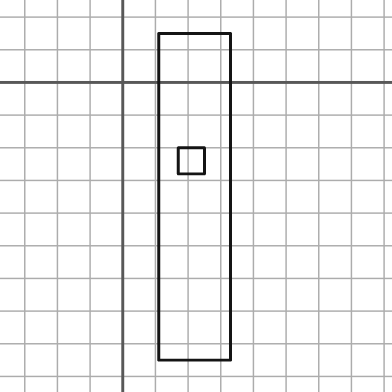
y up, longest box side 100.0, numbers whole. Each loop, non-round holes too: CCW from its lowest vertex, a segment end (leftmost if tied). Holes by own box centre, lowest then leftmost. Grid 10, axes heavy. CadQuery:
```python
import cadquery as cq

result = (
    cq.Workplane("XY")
    .moveTo(11.0, -85.0)
    .lineTo(33.0, -85.0)
    .lineTo(33.0, 15.0)
    .lineTo(11.0, 15.0)
    .close()
    .moveTo(17.0, -28.0)
    .lineTo(25.0, -28.0)
    .lineTo(25.0, -20.0)
    .lineTo(17.0, -20.0)
    .close()
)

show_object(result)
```